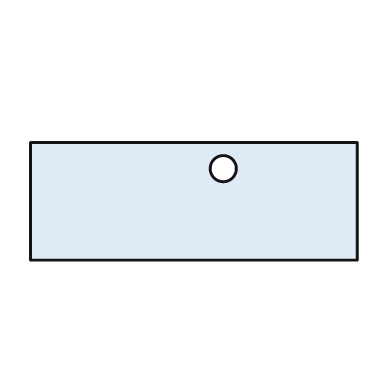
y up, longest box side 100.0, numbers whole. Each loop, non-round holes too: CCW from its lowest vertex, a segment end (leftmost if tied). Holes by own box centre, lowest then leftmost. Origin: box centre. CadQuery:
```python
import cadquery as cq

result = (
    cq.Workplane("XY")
    .moveTo(-50.0, -18.0)
    .lineTo(50.0, -18.0)
    .lineTo(50.0, 18.0)
    .lineTo(-50.0, 18.0)
    .close()
    .moveTo(9.0, 10.0)
    .circle(4.0)
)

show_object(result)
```